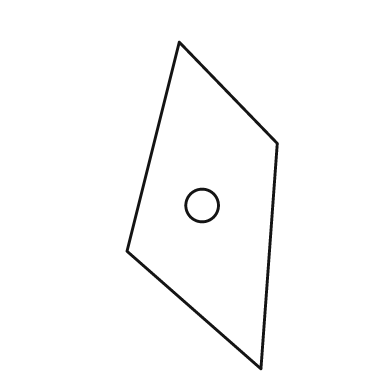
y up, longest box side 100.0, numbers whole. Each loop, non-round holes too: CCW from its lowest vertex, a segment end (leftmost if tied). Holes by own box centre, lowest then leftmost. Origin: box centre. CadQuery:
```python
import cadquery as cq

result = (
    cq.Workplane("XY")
    .moveTo(18.0, -50.0)
    .lineTo(23.0, 19.0)
    .lineTo(-7.0, 50.0)
    .lineTo(-23.0, -14.0)
    .close()
    .moveTo(0.0, 0.0)
    .circle(5.0)
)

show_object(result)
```